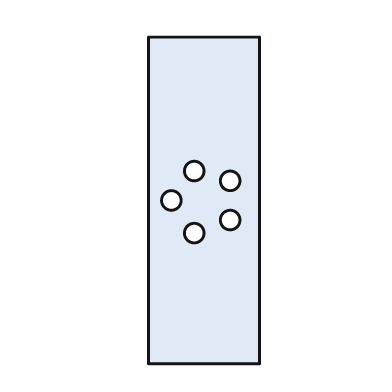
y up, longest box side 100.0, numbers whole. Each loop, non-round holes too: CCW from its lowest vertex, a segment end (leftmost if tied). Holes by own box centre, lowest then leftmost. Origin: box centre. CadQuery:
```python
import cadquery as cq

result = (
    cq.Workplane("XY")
    .moveTo(-17.0, -50.0)
    .lineTo(17.0, -50.0)
    .lineTo(17.0, 50.0)
    .lineTo(-17.0, 50.0)
    .close()
    .moveTo(-3.0, -10.0)
    .circle(3.0)
    .moveTo(8.0, -6.0)
    .circle(3.0)
    .moveTo(-10.0, 0.0)
    .circle(3.0)
    .moveTo(8.0, 6.0)
    .circle(3.0)
    .moveTo(-3.0, 9.0)
    .circle(3.0)
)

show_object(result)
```